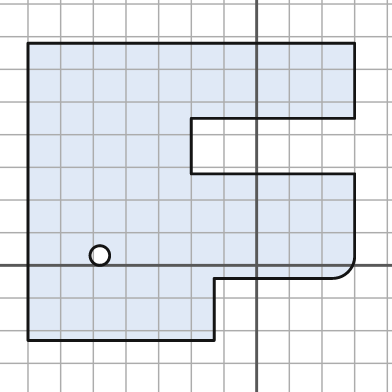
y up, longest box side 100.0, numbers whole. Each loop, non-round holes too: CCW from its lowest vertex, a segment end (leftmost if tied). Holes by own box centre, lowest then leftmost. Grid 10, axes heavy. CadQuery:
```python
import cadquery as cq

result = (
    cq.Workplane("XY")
    .moveTo(-70.0, -23.0)
    .lineTo(-13.0, -23.0)
    .lineTo(-13.0, -4.0)
    .lineTo(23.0, -4.0)
    .threePointArc((28.0, -2.0), (30.0, 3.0))
    .lineTo(30.0, 28.0)
    .lineTo(-20.0, 28.0)
    .lineTo(-20.0, 45.0)
    .lineTo(30.0, 45.0)
    .lineTo(30.0, 68.0)
    .lineTo(-70.0, 68.0)
    .close()
    .moveTo(-48.0, 3.0)
    .circle(3.0)
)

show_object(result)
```